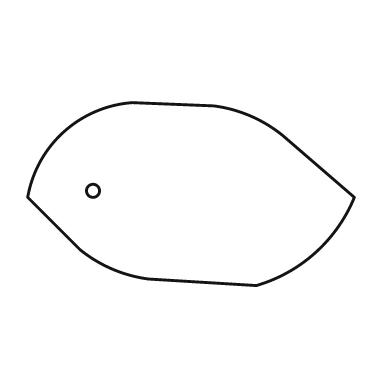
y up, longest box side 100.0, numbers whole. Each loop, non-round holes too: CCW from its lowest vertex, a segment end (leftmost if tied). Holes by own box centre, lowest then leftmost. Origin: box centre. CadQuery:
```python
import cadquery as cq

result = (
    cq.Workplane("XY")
    .moveTo(20.0, -28.0)
    .threePointArc((38.0, -18.0), (50.0, -1.0))
    .lineTo(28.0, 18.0)
    .threePointArc((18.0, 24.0), (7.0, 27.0))
    .lineTo(-18.0, 28.0)
    .threePointArc((-39.0, 19.0), (-50.0, -1.0))
    .lineTo(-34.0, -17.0)
    .threePointArc((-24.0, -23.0), (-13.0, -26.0))
    .close()
    .moveTo(-30.0, 1.0)
    .circle(2.0)
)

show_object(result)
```